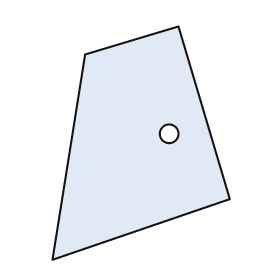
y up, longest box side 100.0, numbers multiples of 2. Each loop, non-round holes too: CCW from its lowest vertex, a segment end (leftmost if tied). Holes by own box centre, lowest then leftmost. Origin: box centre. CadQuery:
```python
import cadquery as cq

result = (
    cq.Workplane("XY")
    .moveTo(-38.0, -50.0)
    .lineTo(38.0, -24.0)
    .lineTo(16.0, 50.0)
    .lineTo(-24.0, 38.0)
    .close()
    .moveTo(12.0, 4.0)
    .circle(4.0)
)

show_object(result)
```